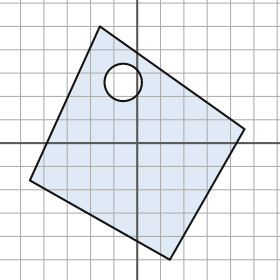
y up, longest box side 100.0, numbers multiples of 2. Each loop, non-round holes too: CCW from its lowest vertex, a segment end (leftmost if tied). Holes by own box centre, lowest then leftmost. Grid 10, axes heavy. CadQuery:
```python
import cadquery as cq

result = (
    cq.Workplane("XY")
    .moveTo(14.0, -50.0)
    .lineTo(46.0, 6.0)
    .lineTo(-16.0, 50.0)
    .lineTo(-46.0, -16.0)
    .close()
    .moveTo(-6.0, 26.0)
    .circle(8.0)
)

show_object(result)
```